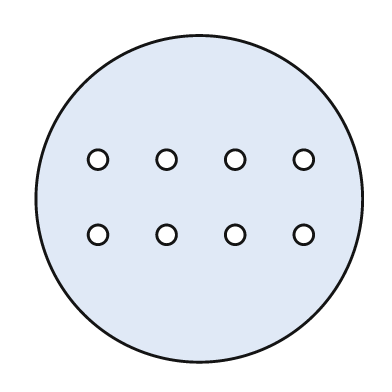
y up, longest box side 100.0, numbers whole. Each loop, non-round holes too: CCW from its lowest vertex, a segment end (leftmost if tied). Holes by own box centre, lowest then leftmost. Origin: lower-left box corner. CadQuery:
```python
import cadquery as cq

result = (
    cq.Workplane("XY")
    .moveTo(50.0, 50.0)
    .circle(50.0)
    .moveTo(19.0, 39.0)
    .circle(3.0)
    .moveTo(40.0, 39.0)
    .circle(3.0)
    .moveTo(61.0, 39.0)
    .circle(3.0)
    .moveTo(82.0, 39.0)
    .circle(3.0)
    .moveTo(19.0, 62.0)
    .circle(3.0)
    .moveTo(40.0, 62.0)
    .circle(3.0)
    .moveTo(61.0, 62.0)
    .circle(3.0)
    .moveTo(82.0, 62.0)
    .circle(3.0)
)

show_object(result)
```